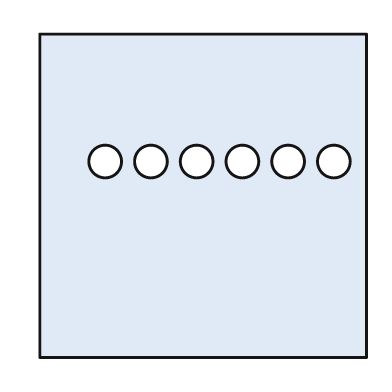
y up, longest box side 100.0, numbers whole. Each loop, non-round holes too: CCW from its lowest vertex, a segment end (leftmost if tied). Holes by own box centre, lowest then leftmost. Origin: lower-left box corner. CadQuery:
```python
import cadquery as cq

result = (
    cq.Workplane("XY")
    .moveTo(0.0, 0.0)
    .lineTo(100.0, 0.0)
    .lineTo(100.0, 99.0)
    .lineTo(0.0, 99.0)
    .close()
    .moveTo(20.0, 60.0)
    .circle(5.0)
    .moveTo(34.0, 60.0)
    .circle(5.0)
    .moveTo(48.0, 60.0)
    .circle(5.0)
    .moveTo(62.0, 60.0)
    .circle(5.0)
    .moveTo(76.0, 60.0)
    .circle(5.0)
    .moveTo(90.0, 60.0)
    .circle(5.0)
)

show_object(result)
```